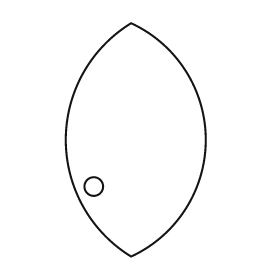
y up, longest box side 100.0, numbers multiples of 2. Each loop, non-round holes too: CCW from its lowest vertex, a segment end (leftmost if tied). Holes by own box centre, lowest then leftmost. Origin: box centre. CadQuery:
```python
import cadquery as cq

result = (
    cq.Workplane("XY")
    .moveTo(-2.0, -50.0)
    .threePointArc((30.0, 0.0), (-2.0, 50.0))
    .threePointArc((-30.0, 0.0), (-2.0, -50.0))
    .close()
    .moveTo(-18.0, -20.0)
    .circle(4.0)
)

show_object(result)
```